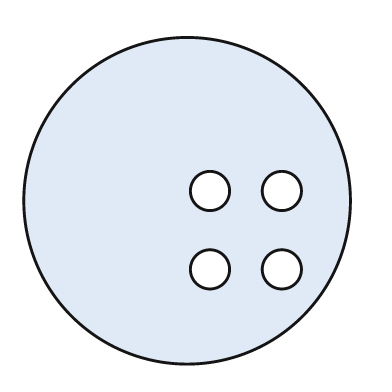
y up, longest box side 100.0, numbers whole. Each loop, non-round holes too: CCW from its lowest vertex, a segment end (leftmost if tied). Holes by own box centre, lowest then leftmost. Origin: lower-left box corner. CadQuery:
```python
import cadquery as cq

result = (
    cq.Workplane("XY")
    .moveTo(50.0, 50.0)
    .circle(50.0)
    .moveTo(57.0, 29.0)
    .circle(6.0)
    .moveTo(79.0, 29.0)
    .circle(6.0)
    .moveTo(57.0, 53.0)
    .circle(6.0)
    .moveTo(79.0, 53.0)
    .circle(6.0)
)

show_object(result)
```